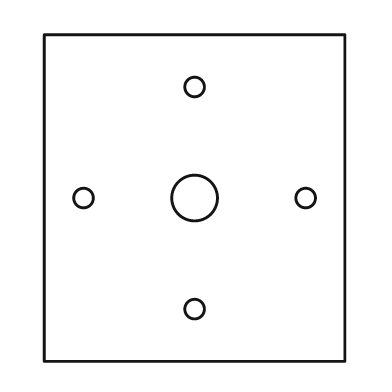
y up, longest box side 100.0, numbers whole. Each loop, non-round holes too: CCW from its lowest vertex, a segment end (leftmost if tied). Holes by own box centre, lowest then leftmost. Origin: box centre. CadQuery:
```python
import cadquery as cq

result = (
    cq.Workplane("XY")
    .moveTo(-46.0, -50.0)
    .lineTo(46.0, -50.0)
    .lineTo(46.0, 50.0)
    .lineTo(-46.0, 50.0)
    .close()
    .moveTo(0.0, -34.0)
    .circle(3.0)
    .moveTo(-34.0, 0.0)
    .circle(3.0)
    .moveTo(0.0, 0.0)
    .circle(7.0)
    .moveTo(34.0, 0.0)
    .circle(3.0)
    .moveTo(0.0, 34.0)
    .circle(3.0)
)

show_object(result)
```